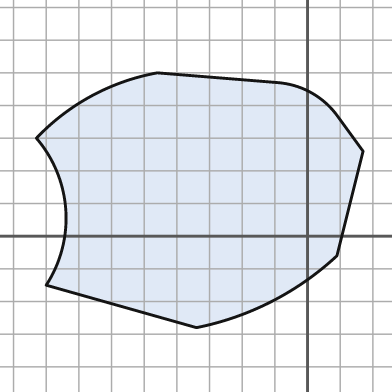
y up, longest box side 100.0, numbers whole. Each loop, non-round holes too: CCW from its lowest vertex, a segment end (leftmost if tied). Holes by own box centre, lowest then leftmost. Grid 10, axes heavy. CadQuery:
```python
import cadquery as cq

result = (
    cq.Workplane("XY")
    .moveTo(-34.0, -28.0)
    .threePointArc((-11.0, -20.0), (9.0, -6.0))
    .lineTo(17.0, 26.0)
    .lineTo(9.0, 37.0)
    .threePointArc((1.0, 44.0), (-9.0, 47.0))
    .lineTo(-46.0, 50.0)
    .threePointArc((-66.0, 43.0), (-83.0, 30.0))
    .threePointArc((-74.0, 8.0), (-80.0, -15.0))
    .close()
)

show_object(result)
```